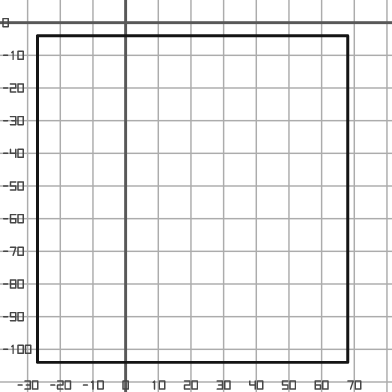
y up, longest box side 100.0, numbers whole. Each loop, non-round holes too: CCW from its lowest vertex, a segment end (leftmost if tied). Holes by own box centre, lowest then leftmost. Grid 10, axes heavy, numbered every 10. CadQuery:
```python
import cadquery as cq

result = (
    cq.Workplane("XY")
    .moveTo(-27.0, -104.0)
    .lineTo(68.0, -104.0)
    .lineTo(68.0, -4.0)
    .lineTo(-27.0, -4.0)
    .close()
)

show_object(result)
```